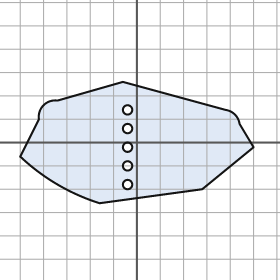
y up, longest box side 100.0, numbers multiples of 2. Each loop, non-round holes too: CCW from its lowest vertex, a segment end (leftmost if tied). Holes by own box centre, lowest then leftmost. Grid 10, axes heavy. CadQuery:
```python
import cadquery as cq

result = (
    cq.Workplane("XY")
    .moveTo(-16.0, -26.0)
    .lineTo(28.0, -20.0)
    .lineTo(50.0, -2.0)
    .lineTo(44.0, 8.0)
    .threePointArc((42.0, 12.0), (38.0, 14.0))
    .lineTo(-6.0, 26.0)
    .lineTo(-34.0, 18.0)
    .threePointArc((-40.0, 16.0), (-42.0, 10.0))
    .lineTo(-50.0, -6.0)
    .threePointArc((-34.0, -18.0), (-16.0, -26.0))
    .close()
    .moveTo(-4.0, -18.0)
    .circle(2.0)
    .moveTo(-4.0, -10.0)
    .circle(2.0)
    .moveTo(-4.0, -2.0)
    .circle(2.0)
    .moveTo(-4.0, 6.0)
    .circle(2.0)
    .moveTo(-4.0, 14.0)
    .circle(2.0)
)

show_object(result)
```